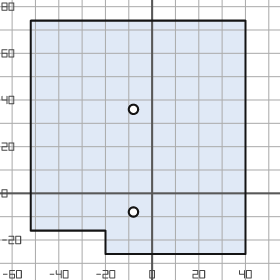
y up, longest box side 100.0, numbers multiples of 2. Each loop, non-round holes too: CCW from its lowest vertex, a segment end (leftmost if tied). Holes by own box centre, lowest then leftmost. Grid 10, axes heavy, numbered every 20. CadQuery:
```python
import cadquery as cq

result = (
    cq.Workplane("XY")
    .moveTo(-20.0, -26.0)
    .lineTo(40.0, -26.0)
    .lineTo(40.0, 74.0)
    .lineTo(-52.0, 74.0)
    .lineTo(-52.0, -16.0)
    .lineTo(-20.0, -16.0)
    .close()
    .moveTo(-8.0, -8.0)
    .circle(2.0)
    .moveTo(-8.0, 36.0)
    .circle(2.0)
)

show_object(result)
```